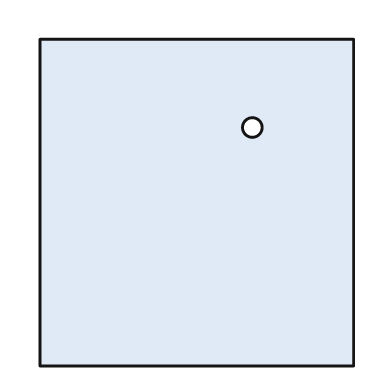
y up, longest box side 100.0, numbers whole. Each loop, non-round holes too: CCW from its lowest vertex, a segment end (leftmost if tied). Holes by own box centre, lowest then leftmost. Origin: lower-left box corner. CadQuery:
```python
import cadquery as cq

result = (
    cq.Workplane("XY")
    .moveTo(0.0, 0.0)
    .lineTo(96.0, 0.0)
    .lineTo(96.0, 100.0)
    .lineTo(0.0, 100.0)
    .close()
    .moveTo(65.0, 73.0)
    .circle(3.0)
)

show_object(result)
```